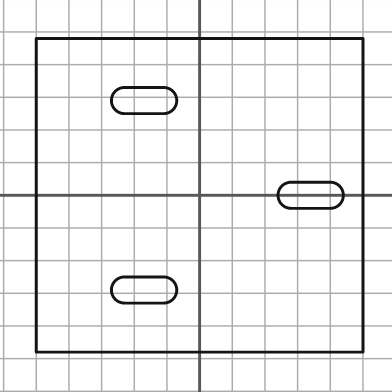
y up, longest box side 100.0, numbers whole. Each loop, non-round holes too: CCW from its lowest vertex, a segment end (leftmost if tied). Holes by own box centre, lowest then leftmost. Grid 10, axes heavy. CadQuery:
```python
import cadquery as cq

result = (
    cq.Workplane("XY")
    .moveTo(-50.0, -48.0)
    .lineTo(50.0, -48.0)
    .lineTo(50.0, 48.0)
    .lineTo(-50.0, 48.0)
    .close()
    .moveTo(-23.0, -33.0)
    .lineTo(-11.0, -33.0)
    .threePointArc((-7.0, -29.0), (-11.0, -25.0))
    .lineTo(-23.0, -25.0)
    .threePointArc((-27.0, -29.0), (-23.0, -33.0))
    .close()
    .moveTo(28.0, -4.0)
    .lineTo(40.0, -4.0)
    .threePointArc((44.0, 0.0), (40.0, 4.0))
    .lineTo(28.0, 4.0)
    .threePointArc((24.0, 0.0), (28.0, -4.0))
    .close()
    .moveTo(-23.0, 25.0)
    .lineTo(-11.0, 25.0)
    .threePointArc((-7.0, 29.0), (-11.0, 33.0))
    .lineTo(-23.0, 33.0)
    .threePointArc((-27.0, 29.0), (-23.0, 25.0))
    .close()
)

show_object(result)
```